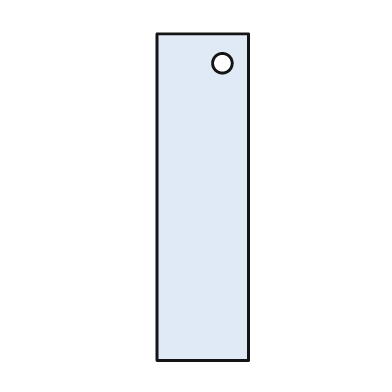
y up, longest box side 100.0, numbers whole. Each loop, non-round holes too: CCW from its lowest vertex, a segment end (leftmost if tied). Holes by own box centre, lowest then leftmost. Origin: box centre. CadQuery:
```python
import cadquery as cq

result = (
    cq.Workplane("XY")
    .moveTo(-14.0, -50.0)
    .lineTo(14.0, -50.0)
    .lineTo(14.0, 50.0)
    .lineTo(-14.0, 50.0)
    .close()
    .moveTo(6.0, 41.0)
    .circle(3.0)
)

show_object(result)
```